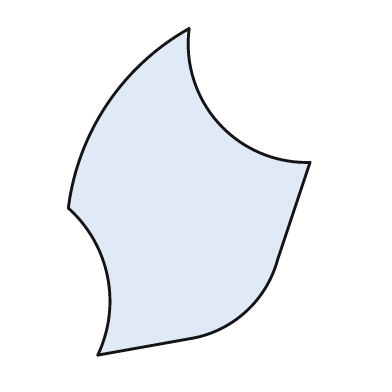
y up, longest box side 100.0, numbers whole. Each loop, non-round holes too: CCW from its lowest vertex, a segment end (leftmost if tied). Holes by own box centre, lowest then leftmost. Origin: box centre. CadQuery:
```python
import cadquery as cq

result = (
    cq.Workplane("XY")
    .moveTo(-28.0, -50.0)
    .lineTo(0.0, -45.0)
    .threePointArc((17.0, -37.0), (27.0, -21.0))
    .lineTo(37.0, 9.0)
    .threePointArc((9.0, 21.0), (0.0, 50.0))
    .threePointArc((-25.0, 27.0), (-37.0, -5.0))
    .threePointArc((-25.0, -26.0), (-28.0, -50.0))
    .close()
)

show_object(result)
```